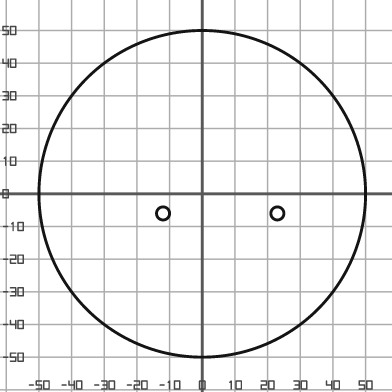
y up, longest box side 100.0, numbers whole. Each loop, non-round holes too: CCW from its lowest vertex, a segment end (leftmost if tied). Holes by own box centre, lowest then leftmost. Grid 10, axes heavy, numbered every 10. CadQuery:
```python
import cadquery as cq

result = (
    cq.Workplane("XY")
    .moveTo(0.0, 0.0)
    .circle(50.0)
    .moveTo(-12.0, -6.0)
    .circle(2.0)
    .moveTo(23.0, -6.0)
    .circle(2.0)
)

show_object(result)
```